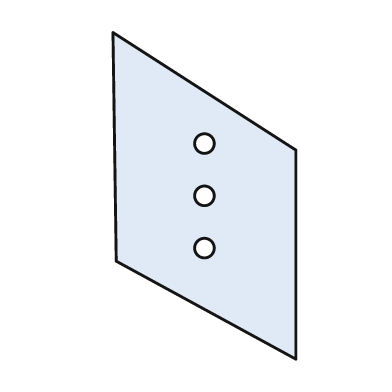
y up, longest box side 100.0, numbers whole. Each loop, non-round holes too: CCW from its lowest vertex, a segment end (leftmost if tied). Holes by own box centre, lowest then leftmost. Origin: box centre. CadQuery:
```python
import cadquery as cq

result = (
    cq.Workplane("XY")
    .moveTo(28.0, -50.0)
    .lineTo(28.0, 14.0)
    .lineTo(-28.0, 50.0)
    .lineTo(-27.0, -20.0)
    .close()
    .moveTo(0.0, -16.0)
    .circle(3.0)
    .moveTo(0.0, 0.0)
    .circle(3.0)
    .moveTo(0.0, 16.0)
    .circle(3.0)
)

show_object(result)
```